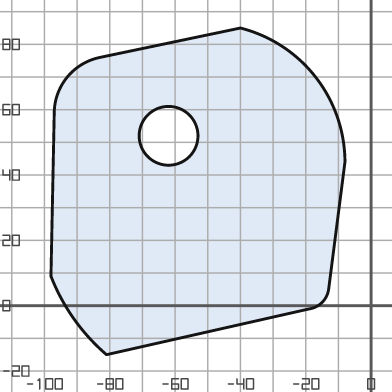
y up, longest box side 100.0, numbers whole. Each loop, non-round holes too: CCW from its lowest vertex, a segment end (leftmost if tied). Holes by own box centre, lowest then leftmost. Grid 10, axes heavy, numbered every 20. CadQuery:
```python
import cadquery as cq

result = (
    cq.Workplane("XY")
    .moveTo(-81.0, -15.0)
    .lineTo(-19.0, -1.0)
    .threePointArc((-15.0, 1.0), (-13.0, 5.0))
    .lineTo(-8.0, 44.0)
    .threePointArc((-17.0, 70.0), (-40.0, 85.0))
    .lineTo(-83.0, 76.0)
    .threePointArc((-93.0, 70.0), (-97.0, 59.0))
    .lineTo(-98.0, 9.0)
    .threePointArc((-91.0, -4.0), (-81.0, -15.0))
    .close()
    .moveTo(-62.0, 52.0)
    .circle(9.0)
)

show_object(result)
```